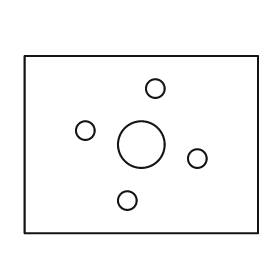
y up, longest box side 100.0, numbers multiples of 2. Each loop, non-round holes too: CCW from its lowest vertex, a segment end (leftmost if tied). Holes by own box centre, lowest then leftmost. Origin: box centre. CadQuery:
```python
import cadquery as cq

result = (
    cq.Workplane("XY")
    .moveTo(-50.0, -38.0)
    .lineTo(50.0, -38.0)
    .lineTo(50.0, 38.0)
    .lineTo(-50.0, 38.0)
    .close()
    .moveTo(-6.0, -24.0)
    .circle(4.0)
    .moveTo(24.0, -6.0)
    .circle(4.0)
    .moveTo(0.0, 0.0)
    .circle(10.0)
    .moveTo(-24.0, 6.0)
    .circle(4.0)
    .moveTo(6.0, 24.0)
    .circle(4.0)
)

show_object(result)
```